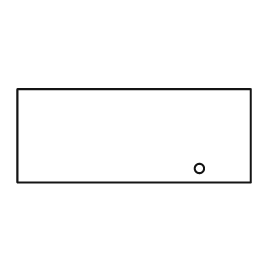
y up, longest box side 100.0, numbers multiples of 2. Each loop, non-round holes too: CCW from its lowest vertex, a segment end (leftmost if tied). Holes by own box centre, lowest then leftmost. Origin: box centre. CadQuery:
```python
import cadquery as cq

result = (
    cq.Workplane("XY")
    .moveTo(-50.0, -20.0)
    .lineTo(50.0, -20.0)
    .lineTo(50.0, 20.0)
    .lineTo(-50.0, 20.0)
    .close()
    .moveTo(28.0, -14.0)
    .circle(2.0)
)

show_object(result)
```